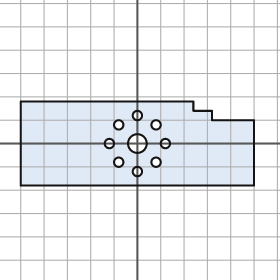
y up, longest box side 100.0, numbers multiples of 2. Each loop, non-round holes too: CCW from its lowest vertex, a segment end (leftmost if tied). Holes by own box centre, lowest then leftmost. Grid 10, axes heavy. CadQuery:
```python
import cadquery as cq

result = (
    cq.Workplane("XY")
    .moveTo(-50.0, -18.0)
    .lineTo(50.0, -18.0)
    .lineTo(50.0, 10.0)
    .lineTo(32.0, 10.0)
    .lineTo(32.0, 14.0)
    .lineTo(24.0, 14.0)
    .lineTo(24.0, 18.0)
    .lineTo(-50.0, 18.0)
    .close()
    .moveTo(0.0, -12.0)
    .circle(2.0)
    .moveTo(-8.0, -8.0)
    .circle(2.0)
    .moveTo(8.0, -8.0)
    .circle(2.0)
    .moveTo(-12.0, 0.0)
    .circle(2.0)
    .moveTo(0.0, 0.0)
    .circle(4.0)
    .moveTo(12.0, 0.0)
    .circle(2.0)
    .moveTo(-8.0, 8.0)
    .circle(2.0)
    .moveTo(8.0, 8.0)
    .circle(2.0)
    .moveTo(0.0, 12.0)
    .circle(2.0)
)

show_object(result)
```